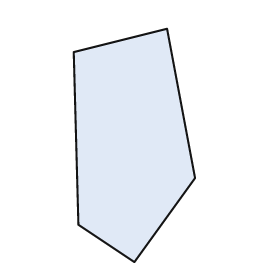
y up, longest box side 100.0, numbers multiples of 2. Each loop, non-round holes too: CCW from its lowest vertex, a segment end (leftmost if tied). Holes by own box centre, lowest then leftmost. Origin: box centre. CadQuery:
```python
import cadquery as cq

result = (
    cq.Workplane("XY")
    .moveTo(0.0, -50.0)
    .lineTo(26.0, -14.0)
    .lineTo(14.0, 50.0)
    .lineTo(-26.0, 40.0)
    .lineTo(-24.0, -34.0)
    .close()
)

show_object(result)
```